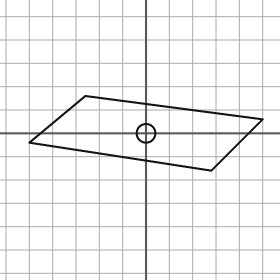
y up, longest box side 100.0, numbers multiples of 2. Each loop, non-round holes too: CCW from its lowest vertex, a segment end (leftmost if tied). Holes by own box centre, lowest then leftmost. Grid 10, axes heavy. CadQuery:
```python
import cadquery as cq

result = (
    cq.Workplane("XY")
    .moveTo(28.0, -16.0)
    .lineTo(50.0, 6.0)
    .lineTo(-26.0, 16.0)
    .lineTo(-50.0, -4.0)
    .close()
    .moveTo(0.0, 0.0)
    .circle(4.0)
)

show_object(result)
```